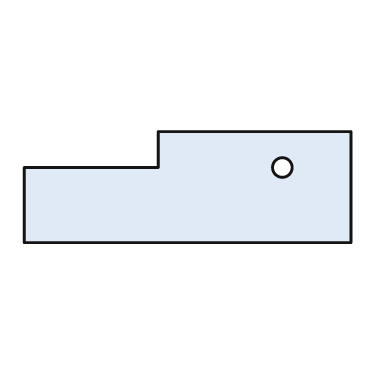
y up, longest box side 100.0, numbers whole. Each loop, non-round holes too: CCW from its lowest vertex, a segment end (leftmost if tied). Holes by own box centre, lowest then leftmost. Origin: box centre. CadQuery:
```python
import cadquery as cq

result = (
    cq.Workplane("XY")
    .moveTo(-50.0, -17.0)
    .lineTo(50.0, -17.0)
    .lineTo(50.0, 17.0)
    .lineTo(-9.0, 17.0)
    .lineTo(-9.0, 6.0)
    .lineTo(-50.0, 6.0)
    .close()
    .moveTo(29.0, 6.0)
    .circle(3.0)
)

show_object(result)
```